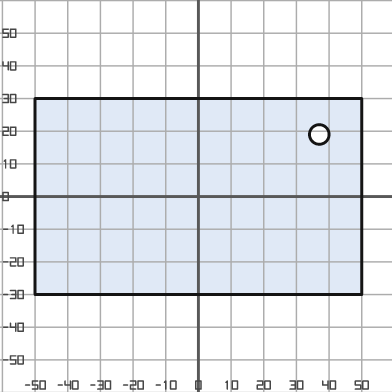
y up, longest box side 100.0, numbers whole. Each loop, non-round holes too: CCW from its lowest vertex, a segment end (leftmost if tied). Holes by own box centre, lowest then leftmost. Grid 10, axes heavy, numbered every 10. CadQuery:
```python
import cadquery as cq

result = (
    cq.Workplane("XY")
    .moveTo(-50.0, -30.0)
    .lineTo(50.0, -30.0)
    .lineTo(50.0, 30.0)
    .lineTo(-50.0, 30.0)
    .close()
    .moveTo(37.0, 19.0)
    .circle(3.0)
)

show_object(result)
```